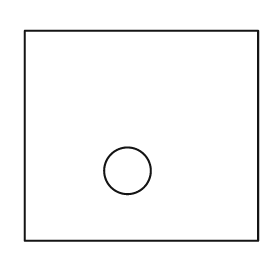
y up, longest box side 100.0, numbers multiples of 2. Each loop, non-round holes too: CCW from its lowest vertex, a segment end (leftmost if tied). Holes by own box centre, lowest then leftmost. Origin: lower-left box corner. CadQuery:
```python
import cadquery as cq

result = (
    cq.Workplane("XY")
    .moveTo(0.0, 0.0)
    .lineTo(100.0, 0.0)
    .lineTo(100.0, 90.0)
    .lineTo(0.0, 90.0)
    .close()
    .moveTo(44.0, 30.0)
    .circle(10.0)
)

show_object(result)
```